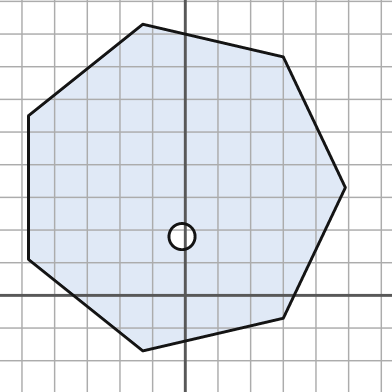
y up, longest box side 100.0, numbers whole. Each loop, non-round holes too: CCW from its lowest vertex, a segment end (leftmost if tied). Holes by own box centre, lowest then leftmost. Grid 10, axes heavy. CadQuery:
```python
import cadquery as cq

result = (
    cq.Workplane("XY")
    .moveTo(-13.0, -17.0)
    .lineTo(30.0, -7.0)
    .lineTo(49.0, 33.0)
    .lineTo(30.0, 73.0)
    .lineTo(-13.0, 83.0)
    .lineTo(-48.0, 55.0)
    .lineTo(-48.0, 11.0)
    .close()
    .moveTo(-1.0, 18.0)
    .circle(4.0)
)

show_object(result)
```